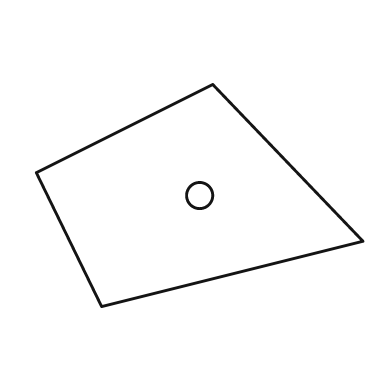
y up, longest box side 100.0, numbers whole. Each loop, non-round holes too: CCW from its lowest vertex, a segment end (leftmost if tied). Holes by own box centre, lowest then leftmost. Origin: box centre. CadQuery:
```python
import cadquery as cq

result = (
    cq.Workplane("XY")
    .moveTo(-30.0, -34.0)
    .lineTo(50.0, -14.0)
    .lineTo(4.0, 34.0)
    .lineTo(-50.0, 7.0)
    .close()
    .moveTo(0.0, 0.0)
    .circle(4.0)
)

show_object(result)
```